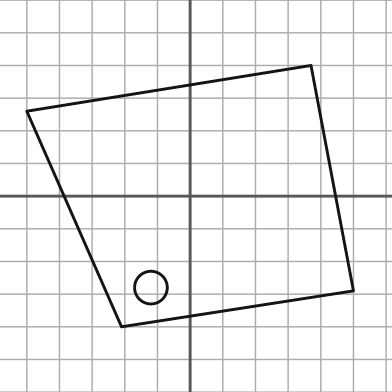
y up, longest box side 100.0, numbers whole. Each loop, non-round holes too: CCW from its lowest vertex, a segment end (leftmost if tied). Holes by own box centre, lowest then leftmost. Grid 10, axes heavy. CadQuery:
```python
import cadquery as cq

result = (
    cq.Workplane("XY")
    .moveTo(-21.0, -40.0)
    .lineTo(50.0, -29.0)
    .lineTo(37.0, 40.0)
    .lineTo(-50.0, 26.0)
    .close()
    .moveTo(-12.0, -28.0)
    .circle(5.0)
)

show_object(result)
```